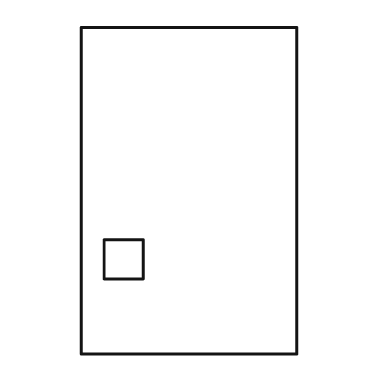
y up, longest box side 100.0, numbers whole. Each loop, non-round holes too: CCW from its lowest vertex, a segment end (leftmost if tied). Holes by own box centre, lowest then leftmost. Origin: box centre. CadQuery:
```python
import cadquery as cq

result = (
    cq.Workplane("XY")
    .moveTo(-33.0, -50.0)
    .lineTo(33.0, -50.0)
    .lineTo(33.0, 50.0)
    .lineTo(-33.0, 50.0)
    .close()
    .moveTo(-26.0, -27.0)
    .lineTo(-14.0, -27.0)
    .lineTo(-14.0, -15.0)
    .lineTo(-26.0, -15.0)
    .close()
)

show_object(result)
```